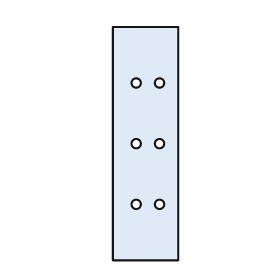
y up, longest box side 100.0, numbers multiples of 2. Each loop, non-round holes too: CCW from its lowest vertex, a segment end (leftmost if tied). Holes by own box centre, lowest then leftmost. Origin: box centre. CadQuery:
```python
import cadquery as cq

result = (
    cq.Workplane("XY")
    .moveTo(-14.0, -50.0)
    .lineTo(14.0, -50.0)
    .lineTo(14.0, 50.0)
    .lineTo(-14.0, 50.0)
    .close()
    .moveTo(-4.0, -26.0)
    .circle(2.0)
    .moveTo(6.0, -26.0)
    .circle(2.0)
    .moveTo(-4.0, 0.0)
    .circle(2.0)
    .moveTo(6.0, 0.0)
    .circle(2.0)
    .moveTo(-4.0, 26.0)
    .circle(2.0)
    .moveTo(6.0, 26.0)
    .circle(2.0)
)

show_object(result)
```